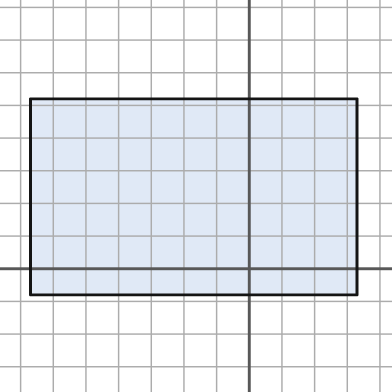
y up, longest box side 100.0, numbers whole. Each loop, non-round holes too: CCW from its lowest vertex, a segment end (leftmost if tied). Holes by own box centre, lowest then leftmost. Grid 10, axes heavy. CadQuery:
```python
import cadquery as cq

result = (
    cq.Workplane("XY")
    .moveTo(-67.0, -8.0)
    .lineTo(33.0, -8.0)
    .lineTo(33.0, 52.0)
    .lineTo(-67.0, 52.0)
    .close()
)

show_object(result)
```